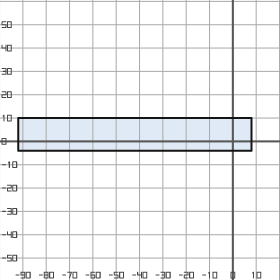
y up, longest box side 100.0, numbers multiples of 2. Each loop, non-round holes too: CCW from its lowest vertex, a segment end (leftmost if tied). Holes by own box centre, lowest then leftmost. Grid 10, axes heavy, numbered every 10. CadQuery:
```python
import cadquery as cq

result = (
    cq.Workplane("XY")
    .moveTo(-92.0, -4.0)
    .lineTo(8.0, -4.0)
    .lineTo(8.0, 10.0)
    .lineTo(-92.0, 10.0)
    .close()
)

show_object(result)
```